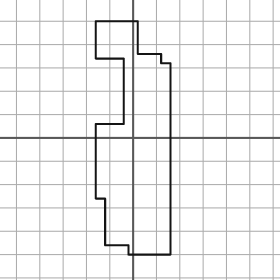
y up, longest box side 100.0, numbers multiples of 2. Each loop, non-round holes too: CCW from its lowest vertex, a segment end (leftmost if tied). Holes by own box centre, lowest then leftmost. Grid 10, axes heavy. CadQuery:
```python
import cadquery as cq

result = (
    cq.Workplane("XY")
    .moveTo(-2.0, -50.0)
    .lineTo(16.0, -50.0)
    .lineTo(16.0, 32.0)
    .lineTo(12.0, 32.0)
    .lineTo(12.0, 36.0)
    .lineTo(2.0, 36.0)
    .lineTo(2.0, 50.0)
    .lineTo(-16.0, 50.0)
    .lineTo(-16.0, 34.0)
    .lineTo(-4.0, 34.0)
    .lineTo(-4.0, 6.0)
    .lineTo(-16.0, 6.0)
    .lineTo(-16.0, -26.0)
    .lineTo(-12.0, -26.0)
    .lineTo(-12.0, -46.0)
    .lineTo(-2.0, -46.0)
    .close()
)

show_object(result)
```